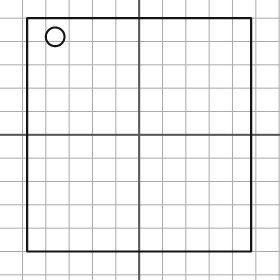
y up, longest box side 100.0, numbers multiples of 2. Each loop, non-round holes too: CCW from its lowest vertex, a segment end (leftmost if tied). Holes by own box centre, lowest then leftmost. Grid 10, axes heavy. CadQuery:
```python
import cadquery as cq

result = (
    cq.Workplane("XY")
    .moveTo(-48.0, -50.0)
    .lineTo(48.0, -50.0)
    .lineTo(48.0, 50.0)
    .lineTo(-48.0, 50.0)
    .close()
    .moveTo(-36.0, 42.0)
    .circle(4.0)
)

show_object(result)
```